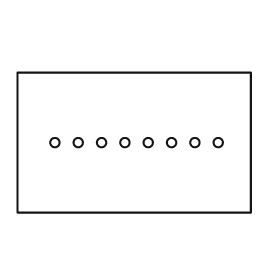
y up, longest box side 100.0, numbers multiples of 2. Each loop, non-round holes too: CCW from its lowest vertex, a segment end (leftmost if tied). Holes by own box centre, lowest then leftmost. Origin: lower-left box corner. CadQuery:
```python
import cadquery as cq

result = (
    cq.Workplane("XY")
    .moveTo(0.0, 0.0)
    .lineTo(100.0, 0.0)
    .lineTo(100.0, 60.0)
    .lineTo(0.0, 60.0)
    .close()
    .moveTo(16.0, 30.0)
    .circle(2.0)
    .moveTo(26.0, 30.0)
    .circle(2.0)
    .moveTo(36.0, 30.0)
    .circle(2.0)
    .moveTo(46.0, 30.0)
    .circle(2.0)
    .moveTo(56.0, 30.0)
    .circle(2.0)
    .moveTo(66.0, 30.0)
    .circle(2.0)
    .moveTo(76.0, 30.0)
    .circle(2.0)
    .moveTo(86.0, 30.0)
    .circle(2.0)
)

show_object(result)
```